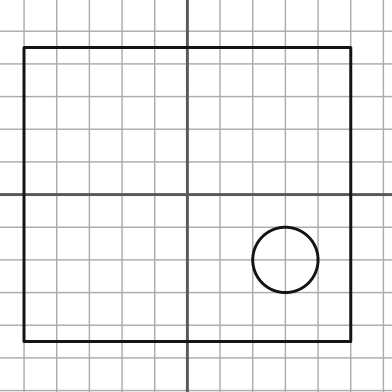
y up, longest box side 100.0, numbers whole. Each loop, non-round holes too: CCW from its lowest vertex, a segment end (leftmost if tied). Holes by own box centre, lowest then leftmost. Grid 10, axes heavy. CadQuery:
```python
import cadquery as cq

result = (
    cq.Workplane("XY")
    .moveTo(-50.0, -45.0)
    .lineTo(50.0, -45.0)
    .lineTo(50.0, 45.0)
    .lineTo(-50.0, 45.0)
    .close()
    .moveTo(30.0, -20.0)
    .circle(10.0)
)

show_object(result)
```